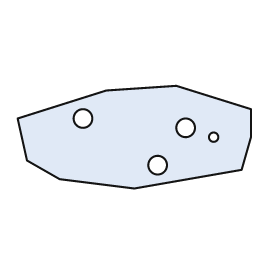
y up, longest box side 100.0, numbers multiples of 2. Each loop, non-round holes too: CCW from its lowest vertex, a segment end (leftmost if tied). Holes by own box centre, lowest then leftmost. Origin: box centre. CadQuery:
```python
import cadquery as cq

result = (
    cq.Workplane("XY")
    .moveTo(0.0, -22.0)
    .lineTo(46.0, -14.0)
    .lineTo(50.0, 0.0)
    .lineTo(50.0, 12.0)
    .lineTo(18.0, 22.0)
    .lineTo(-12.0, 20.0)
    .lineTo(-50.0, 8.0)
    .lineTo(-46.0, -10.0)
    .lineTo(-32.0, -18.0)
    .close()
    .moveTo(10.0, -12.0)
    .circle(4.0)
    .moveTo(34.0, 0.0)
    .circle(2.0)
    .moveTo(22.0, 4.0)
    .circle(4.0)
    .moveTo(-22.0, 8.0)
    .circle(4.0)
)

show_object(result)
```